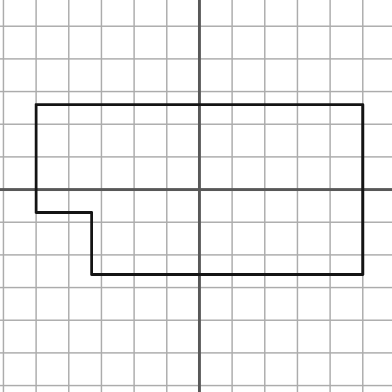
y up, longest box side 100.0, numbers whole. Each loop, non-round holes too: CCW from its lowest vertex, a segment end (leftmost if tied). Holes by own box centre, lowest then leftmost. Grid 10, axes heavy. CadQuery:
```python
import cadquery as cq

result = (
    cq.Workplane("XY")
    .moveTo(-33.0, -26.0)
    .lineTo(50.0, -26.0)
    .lineTo(50.0, 26.0)
    .lineTo(-50.0, 26.0)
    .lineTo(-50.0, -7.0)
    .lineTo(-33.0, -7.0)
    .close()
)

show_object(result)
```